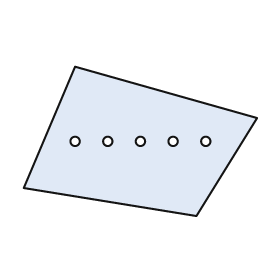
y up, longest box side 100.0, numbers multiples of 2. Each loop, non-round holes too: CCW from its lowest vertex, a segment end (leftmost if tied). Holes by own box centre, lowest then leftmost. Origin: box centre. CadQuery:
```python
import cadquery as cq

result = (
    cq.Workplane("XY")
    .moveTo(24.0, -32.0)
    .lineTo(50.0, 10.0)
    .lineTo(-28.0, 32.0)
    .lineTo(-50.0, -20.0)
    .close()
    .moveTo(-28.0, 0.0)
    .circle(2.0)
    .moveTo(-14.0, 0.0)
    .circle(2.0)
    .moveTo(0.0, 0.0)
    .circle(2.0)
    .moveTo(14.0, 0.0)
    .circle(2.0)
    .moveTo(28.0, 0.0)
    .circle(2.0)
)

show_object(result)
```